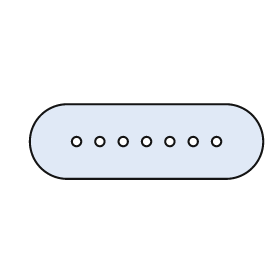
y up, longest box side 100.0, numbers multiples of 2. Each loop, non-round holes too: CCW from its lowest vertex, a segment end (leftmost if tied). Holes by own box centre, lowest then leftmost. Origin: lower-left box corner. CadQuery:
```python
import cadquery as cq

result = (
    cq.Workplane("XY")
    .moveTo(16.0, 0.0)
    .lineTo(84.0, 0.0)
    .threePointArc((100.0, 16.0), (84.0, 32.0))
    .lineTo(16.0, 32.0)
    .threePointArc((0.0, 16.0), (16.0, 0.0))
    .close()
    .moveTo(20.0, 16.0)
    .circle(2.0)
    .moveTo(30.0, 16.0)
    .circle(2.0)
    .moveTo(40.0, 16.0)
    .circle(2.0)
    .moveTo(50.0, 16.0)
    .circle(2.0)
    .moveTo(60.0, 16.0)
    .circle(2.0)
    .moveTo(70.0, 16.0)
    .circle(2.0)
    .moveTo(80.0, 16.0)
    .circle(2.0)
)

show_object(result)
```